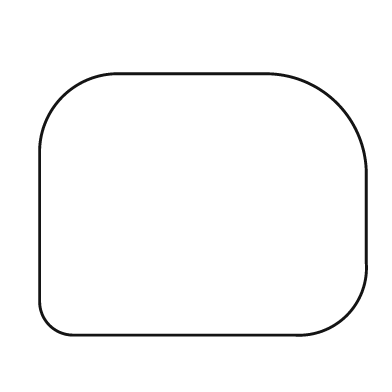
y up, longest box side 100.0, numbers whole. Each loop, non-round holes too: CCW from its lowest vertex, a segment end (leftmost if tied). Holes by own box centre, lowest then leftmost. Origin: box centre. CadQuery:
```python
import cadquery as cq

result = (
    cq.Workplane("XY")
    .moveTo(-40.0, -40.0)
    .lineTo(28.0, -40.0)
    .threePointArc((44.0, -34.0), (50.0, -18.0))
    .lineTo(50.0, 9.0)
    .threePointArc((41.0, 31.0), (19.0, 40.0))
    .lineTo(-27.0, 40.0)
    .threePointArc((-43.0, 33.0), (-50.0, 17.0))
    .lineTo(-50.0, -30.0)
    .threePointArc((-47.0, -37.0), (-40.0, -40.0))
    .close()
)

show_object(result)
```